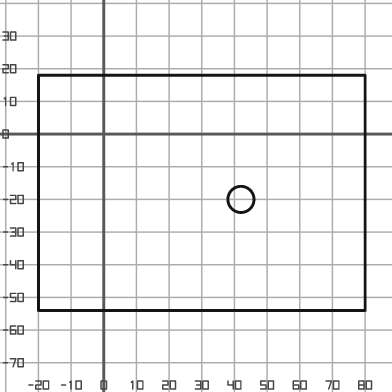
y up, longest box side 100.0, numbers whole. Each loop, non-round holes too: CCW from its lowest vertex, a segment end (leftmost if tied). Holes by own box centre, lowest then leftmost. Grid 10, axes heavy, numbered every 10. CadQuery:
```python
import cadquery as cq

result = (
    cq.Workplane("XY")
    .moveTo(-20.0, -54.0)
    .lineTo(80.0, -54.0)
    .lineTo(80.0, 18.0)
    .lineTo(-20.0, 18.0)
    .close()
    .moveTo(42.0, -20.0)
    .circle(4.0)
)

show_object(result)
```